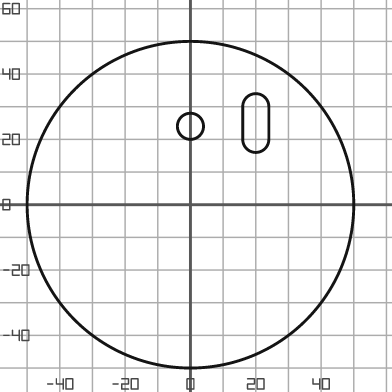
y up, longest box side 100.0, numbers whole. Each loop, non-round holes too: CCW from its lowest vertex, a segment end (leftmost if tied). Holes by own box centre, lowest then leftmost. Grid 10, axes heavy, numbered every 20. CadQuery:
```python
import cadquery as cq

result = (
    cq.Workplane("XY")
    .moveTo(0.0, 0.0)
    .circle(50.0)
    .moveTo(0.0, 24.0)
    .circle(4.0)
    .moveTo(16.0, 20.0)
    .threePointArc((20.0, 16.0), (24.0, 20.0))
    .lineTo(24.0, 30.0)
    .threePointArc((20.0, 34.0), (16.0, 30.0))
    .close()
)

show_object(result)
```